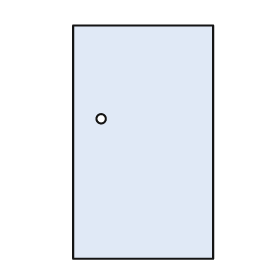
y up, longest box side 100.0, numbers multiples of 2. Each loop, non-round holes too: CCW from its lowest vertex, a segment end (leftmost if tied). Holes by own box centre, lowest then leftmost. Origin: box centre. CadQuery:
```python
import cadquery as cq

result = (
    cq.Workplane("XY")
    .moveTo(-30.0, -50.0)
    .lineTo(30.0, -50.0)
    .lineTo(30.0, 50.0)
    .lineTo(-30.0, 50.0)
    .close()
    .moveTo(-18.0, 10.0)
    .circle(2.0)
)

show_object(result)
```